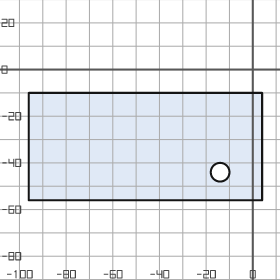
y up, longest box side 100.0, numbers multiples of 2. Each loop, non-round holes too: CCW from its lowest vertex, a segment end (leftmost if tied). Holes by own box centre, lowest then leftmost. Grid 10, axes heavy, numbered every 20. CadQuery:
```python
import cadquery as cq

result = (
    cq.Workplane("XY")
    .moveTo(-96.0, -56.0)
    .lineTo(4.0, -56.0)
    .lineTo(4.0, -10.0)
    .lineTo(-96.0, -10.0)
    .close()
    .moveTo(-14.0, -44.0)
    .circle(4.0)
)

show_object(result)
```